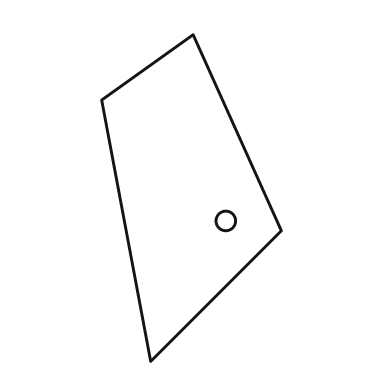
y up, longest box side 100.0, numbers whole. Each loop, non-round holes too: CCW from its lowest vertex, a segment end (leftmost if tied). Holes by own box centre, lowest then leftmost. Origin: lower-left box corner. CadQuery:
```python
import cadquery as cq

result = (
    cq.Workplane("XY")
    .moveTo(15.0, 0.0)
    .lineTo(55.0, 40.0)
    .lineTo(28.0, 100.0)
    .lineTo(0.0, 80.0)
    .close()
    .moveTo(38.0, 43.0)
    .circle(3.0)
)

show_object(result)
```